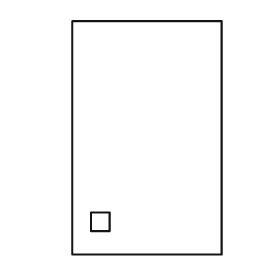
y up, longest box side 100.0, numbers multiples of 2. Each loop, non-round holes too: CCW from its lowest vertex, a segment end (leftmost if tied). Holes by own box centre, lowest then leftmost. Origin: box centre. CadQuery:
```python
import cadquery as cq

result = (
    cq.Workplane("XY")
    .moveTo(-32.0, -50.0)
    .lineTo(32.0, -50.0)
    .lineTo(32.0, 50.0)
    .lineTo(-32.0, 50.0)
    .close()
    .moveTo(-24.0, -40.0)
    .lineTo(-16.0, -40.0)
    .lineTo(-16.0, -32.0)
    .lineTo(-24.0, -32.0)
    .close()
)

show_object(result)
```